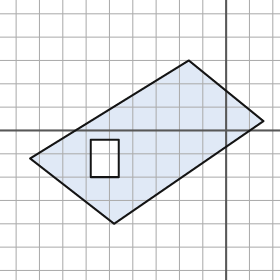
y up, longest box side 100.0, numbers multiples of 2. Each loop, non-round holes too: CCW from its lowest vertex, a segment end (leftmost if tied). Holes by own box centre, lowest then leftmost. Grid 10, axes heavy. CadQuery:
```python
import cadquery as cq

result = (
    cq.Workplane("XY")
    .moveTo(-48.0, -40.0)
    .lineTo(16.0, 4.0)
    .lineTo(-16.0, 30.0)
    .lineTo(-84.0, -12.0)
    .close()
    .moveTo(-58.0, -20.0)
    .lineTo(-46.0, -20.0)
    .lineTo(-46.0, -4.0)
    .lineTo(-58.0, -4.0)
    .close()
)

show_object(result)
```